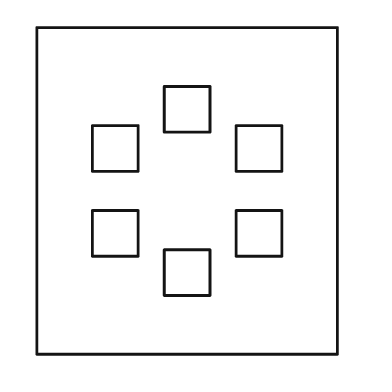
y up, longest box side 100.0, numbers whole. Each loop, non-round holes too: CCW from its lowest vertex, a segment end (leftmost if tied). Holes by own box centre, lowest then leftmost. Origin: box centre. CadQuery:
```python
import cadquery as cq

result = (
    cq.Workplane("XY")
    .moveTo(-46.0, -50.0)
    .lineTo(46.0, -50.0)
    .lineTo(46.0, 50.0)
    .lineTo(-46.0, 50.0)
    .close()
    .moveTo(-7.0, -32.0)
    .lineTo(7.0, -32.0)
    .lineTo(7.0, -18.0)
    .lineTo(-7.0, -18.0)
    .close()
    .moveTo(-29.0, -20.0)
    .lineTo(-15.0, -20.0)
    .lineTo(-15.0, -6.0)
    .lineTo(-29.0, -6.0)
    .close()
    .moveTo(15.0, -20.0)
    .lineTo(29.0, -20.0)
    .lineTo(29.0, -6.0)
    .lineTo(15.0, -6.0)
    .close()
    .moveTo(-29.0, 6.0)
    .lineTo(-15.0, 6.0)
    .lineTo(-15.0, 20.0)
    .lineTo(-29.0, 20.0)
    .close()
    .moveTo(15.0, 6.0)
    .lineTo(29.0, 6.0)
    .lineTo(29.0, 20.0)
    .lineTo(15.0, 20.0)
    .close()
    .moveTo(-7.0, 18.0)
    .lineTo(7.0, 18.0)
    .lineTo(7.0, 32.0)
    .lineTo(-7.0, 32.0)
    .close()
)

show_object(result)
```